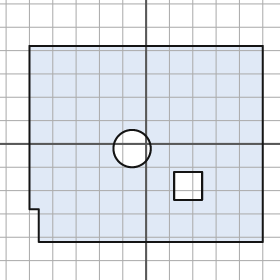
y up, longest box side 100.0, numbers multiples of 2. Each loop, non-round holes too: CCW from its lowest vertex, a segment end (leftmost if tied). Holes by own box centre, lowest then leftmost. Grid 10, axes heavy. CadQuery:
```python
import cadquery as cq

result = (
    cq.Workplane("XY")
    .moveTo(-46.0, -42.0)
    .lineTo(50.0, -42.0)
    .lineTo(50.0, 42.0)
    .lineTo(-50.0, 42.0)
    .lineTo(-50.0, -28.0)
    .lineTo(-46.0, -28.0)
    .close()
    .moveTo(12.0, -24.0)
    .lineTo(24.0, -24.0)
    .lineTo(24.0, -12.0)
    .lineTo(12.0, -12.0)
    .close()
    .moveTo(-6.0, -2.0)
    .circle(8.0)
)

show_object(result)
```